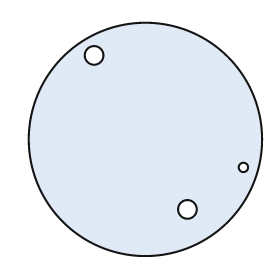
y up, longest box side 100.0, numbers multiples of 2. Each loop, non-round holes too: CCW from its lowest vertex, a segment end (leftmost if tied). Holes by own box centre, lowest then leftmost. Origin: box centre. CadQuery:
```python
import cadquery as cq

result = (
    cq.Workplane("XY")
    .moveTo(0.0, 0.0)
    .circle(50.0)
    .moveTo(18.0, -30.0)
    .circle(4.0)
    .moveTo(42.0, -12.0)
    .circle(2.0)
    .moveTo(-22.0, 36.0)
    .circle(4.0)
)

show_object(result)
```